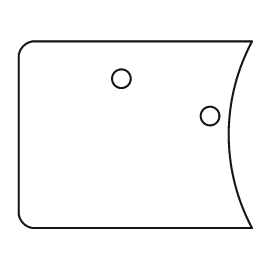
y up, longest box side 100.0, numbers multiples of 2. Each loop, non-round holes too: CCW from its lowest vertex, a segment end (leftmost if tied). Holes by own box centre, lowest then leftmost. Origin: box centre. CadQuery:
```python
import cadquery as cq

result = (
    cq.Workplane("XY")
    .moveTo(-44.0, -40.0)
    .lineTo(50.0, -40.0)
    .threePointArc((40.0, 0.0), (50.0, 40.0))
    .lineTo(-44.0, 40.0)
    .threePointArc((-48.0, 38.0), (-50.0, 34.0))
    .lineTo(-50.0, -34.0)
    .threePointArc((-48.0, -38.0), (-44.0, -40.0))
    .close()
    .moveTo(32.0, 8.0)
    .circle(4.0)
    .moveTo(-6.0, 24.0)
    .circle(4.0)
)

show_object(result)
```